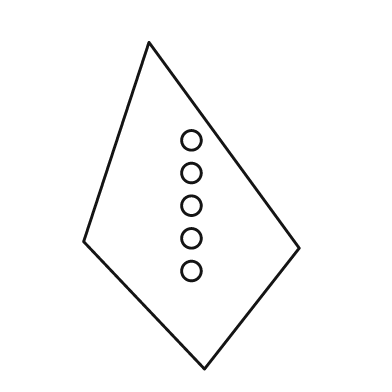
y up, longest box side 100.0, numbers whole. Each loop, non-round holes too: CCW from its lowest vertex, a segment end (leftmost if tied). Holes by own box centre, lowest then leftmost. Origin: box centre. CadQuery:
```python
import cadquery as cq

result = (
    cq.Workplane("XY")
    .moveTo(4.0, -50.0)
    .lineTo(33.0, -13.0)
    .lineTo(-13.0, 50.0)
    .lineTo(-33.0, -11.0)
    .close()
    .moveTo(0.0, -20.0)
    .circle(3.0)
    .moveTo(0.0, -10.0)
    .circle(3.0)
    .moveTo(0.0, 0.0)
    .circle(3.0)
    .moveTo(0.0, 10.0)
    .circle(3.0)
    .moveTo(0.0, 20.0)
    .circle(3.0)
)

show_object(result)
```